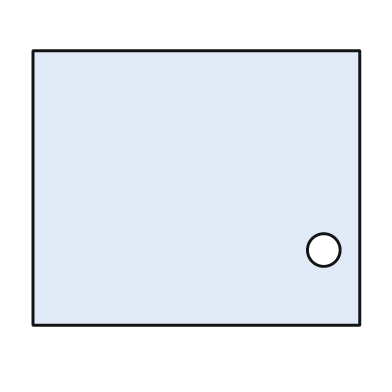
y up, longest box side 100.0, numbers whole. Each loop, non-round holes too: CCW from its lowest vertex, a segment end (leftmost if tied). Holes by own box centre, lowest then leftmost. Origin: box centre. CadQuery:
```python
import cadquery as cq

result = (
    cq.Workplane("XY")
    .moveTo(-50.0, -42.0)
    .lineTo(50.0, -42.0)
    .lineTo(50.0, 42.0)
    .lineTo(-50.0, 42.0)
    .close()
    .moveTo(39.0, -19.0)
    .circle(5.0)
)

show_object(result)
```